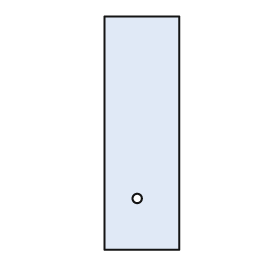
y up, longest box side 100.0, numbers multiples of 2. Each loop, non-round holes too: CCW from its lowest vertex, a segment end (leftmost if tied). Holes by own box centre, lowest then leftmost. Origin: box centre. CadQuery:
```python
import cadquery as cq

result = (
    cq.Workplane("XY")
    .moveTo(-16.0, -50.0)
    .lineTo(16.0, -50.0)
    .lineTo(16.0, 50.0)
    .lineTo(-16.0, 50.0)
    .close()
    .moveTo(-2.0, -28.0)
    .circle(2.0)
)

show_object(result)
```